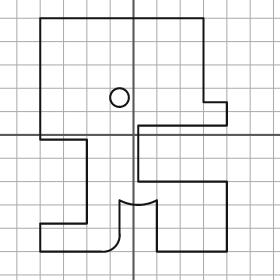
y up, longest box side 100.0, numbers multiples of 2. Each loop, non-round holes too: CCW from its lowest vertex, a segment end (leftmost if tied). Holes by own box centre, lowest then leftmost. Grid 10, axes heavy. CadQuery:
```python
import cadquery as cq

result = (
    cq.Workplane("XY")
    .moveTo(-40.0, -50.0)
    .lineTo(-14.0, -50.0)
    .threePointArc((-8.0, -48.0), (-6.0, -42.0))
    .lineTo(-6.0, -28.0)
    .threePointArc((2.0, -30.0), (10.0, -28.0))
    .lineTo(10.0, -50.0)
    .lineTo(40.0, -50.0)
    .lineTo(40.0, -20.0)
    .lineTo(2.0, -20.0)
    .lineTo(2.0, 4.0)
    .lineTo(40.0, 4.0)
    .lineTo(40.0, 14.0)
    .lineTo(30.0, 14.0)
    .lineTo(30.0, 50.0)
    .lineTo(-40.0, 50.0)
    .lineTo(-40.0, -2.0)
    .lineTo(-20.0, -2.0)
    .lineTo(-20.0, -38.0)
    .lineTo(-40.0, -38.0)
    .close()
    .moveTo(-6.0, 16.0)
    .circle(4.0)
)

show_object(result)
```